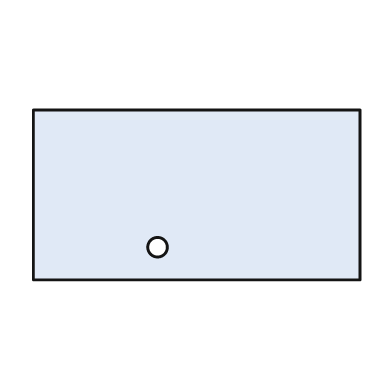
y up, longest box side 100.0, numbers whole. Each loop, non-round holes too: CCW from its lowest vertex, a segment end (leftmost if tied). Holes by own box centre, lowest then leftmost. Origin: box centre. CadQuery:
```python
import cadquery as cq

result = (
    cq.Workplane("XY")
    .moveTo(-50.0, -26.0)
    .lineTo(50.0, -26.0)
    .lineTo(50.0, 26.0)
    .lineTo(-50.0, 26.0)
    .close()
    .moveTo(-12.0, -16.0)
    .circle(3.0)
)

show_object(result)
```